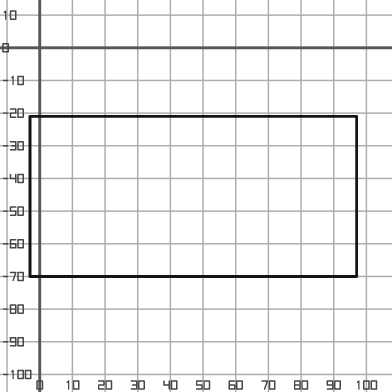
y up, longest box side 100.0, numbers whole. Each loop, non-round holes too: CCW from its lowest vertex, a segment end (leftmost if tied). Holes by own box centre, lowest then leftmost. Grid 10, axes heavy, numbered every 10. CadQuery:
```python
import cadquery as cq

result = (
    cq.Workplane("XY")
    .moveTo(-3.0, -70.0)
    .lineTo(97.0, -70.0)
    .lineTo(97.0, -21.0)
    .lineTo(-3.0, -21.0)
    .close()
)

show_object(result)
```